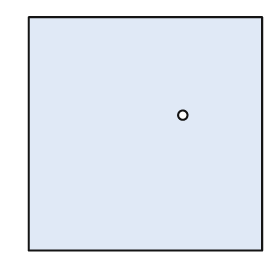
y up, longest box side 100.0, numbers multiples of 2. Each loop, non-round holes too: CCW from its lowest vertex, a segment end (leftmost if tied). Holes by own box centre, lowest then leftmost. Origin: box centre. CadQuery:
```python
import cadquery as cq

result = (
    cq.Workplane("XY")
    .moveTo(-50.0, -50.0)
    .lineTo(50.0, -50.0)
    .lineTo(50.0, 50.0)
    .lineTo(-50.0, 50.0)
    .close()
    .moveTo(16.0, 8.0)
    .circle(2.0)
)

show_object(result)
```